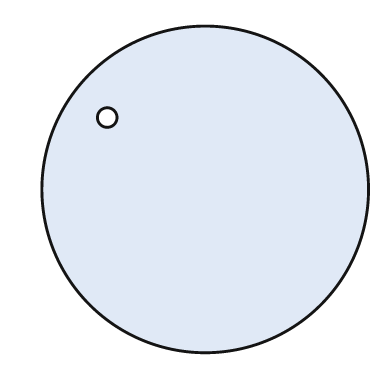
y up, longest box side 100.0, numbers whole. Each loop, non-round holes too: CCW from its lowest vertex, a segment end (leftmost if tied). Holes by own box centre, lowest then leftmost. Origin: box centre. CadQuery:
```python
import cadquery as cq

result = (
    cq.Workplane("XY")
    .moveTo(0.0, 0.0)
    .circle(50.0)
    .moveTo(-30.0, 22.0)
    .circle(3.0)
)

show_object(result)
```